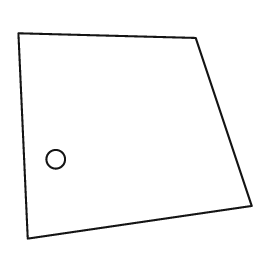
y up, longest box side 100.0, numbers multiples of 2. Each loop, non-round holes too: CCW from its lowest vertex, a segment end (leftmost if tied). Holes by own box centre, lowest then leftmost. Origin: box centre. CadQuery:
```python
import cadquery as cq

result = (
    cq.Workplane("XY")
    .moveTo(-46.0, -44.0)
    .lineTo(50.0, -30.0)
    .lineTo(26.0, 42.0)
    .lineTo(-50.0, 44.0)
    .close()
    .moveTo(-34.0, -10.0)
    .circle(4.0)
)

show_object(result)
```